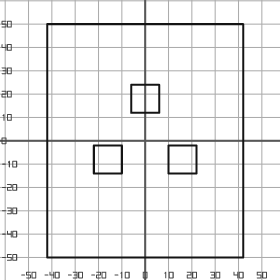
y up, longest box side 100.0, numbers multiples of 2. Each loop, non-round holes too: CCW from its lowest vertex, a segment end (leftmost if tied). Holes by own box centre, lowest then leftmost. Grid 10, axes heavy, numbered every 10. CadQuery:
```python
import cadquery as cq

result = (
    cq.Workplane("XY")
    .moveTo(-42.0, -50.0)
    .lineTo(42.0, -50.0)
    .lineTo(42.0, 50.0)
    .lineTo(-42.0, 50.0)
    .close()
    .moveTo(-22.0, -14.0)
    .lineTo(-10.0, -14.0)
    .lineTo(-10.0, -2.0)
    .lineTo(-22.0, -2.0)
    .close()
    .moveTo(10.0, -14.0)
    .lineTo(22.0, -14.0)
    .lineTo(22.0, -2.0)
    .lineTo(10.0, -2.0)
    .close()
    .moveTo(-6.0, 12.0)
    .lineTo(6.0, 12.0)
    .lineTo(6.0, 24.0)
    .lineTo(-6.0, 24.0)
    .close()
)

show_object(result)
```